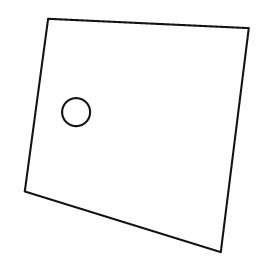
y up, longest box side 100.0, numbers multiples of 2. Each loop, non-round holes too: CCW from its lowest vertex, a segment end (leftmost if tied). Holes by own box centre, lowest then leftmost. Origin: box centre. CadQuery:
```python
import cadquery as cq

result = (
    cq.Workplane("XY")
    .moveTo(36.0, -50.0)
    .lineTo(48.0, 46.0)
    .lineTo(-38.0, 50.0)
    .lineTo(-48.0, -24.0)
    .close()
    .moveTo(-26.0, 10.0)
    .circle(6.0)
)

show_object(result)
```